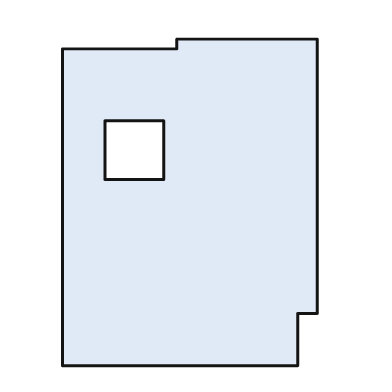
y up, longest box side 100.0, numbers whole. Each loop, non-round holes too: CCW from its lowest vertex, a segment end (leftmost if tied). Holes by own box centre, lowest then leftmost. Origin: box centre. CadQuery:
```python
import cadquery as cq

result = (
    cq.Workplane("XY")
    .moveTo(-39.0, -50.0)
    .lineTo(33.0, -50.0)
    .lineTo(33.0, -34.0)
    .lineTo(39.0, -34.0)
    .lineTo(39.0, 50.0)
    .lineTo(-4.0, 50.0)
    .lineTo(-4.0, 47.0)
    .lineTo(-39.0, 47.0)
    .close()
    .moveTo(-26.0, 7.0)
    .lineTo(-8.0, 7.0)
    .lineTo(-8.0, 25.0)
    .lineTo(-26.0, 25.0)
    .close()
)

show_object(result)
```